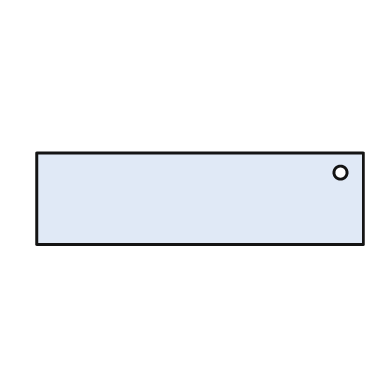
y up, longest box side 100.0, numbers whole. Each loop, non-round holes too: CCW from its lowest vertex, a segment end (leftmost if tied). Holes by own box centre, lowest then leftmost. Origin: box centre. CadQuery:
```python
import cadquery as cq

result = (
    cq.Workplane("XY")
    .moveTo(-50.0, -14.0)
    .lineTo(50.0, -14.0)
    .lineTo(50.0, 14.0)
    .lineTo(-50.0, 14.0)
    .close()
    .moveTo(43.0, 8.0)
    .circle(2.0)
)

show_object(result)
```